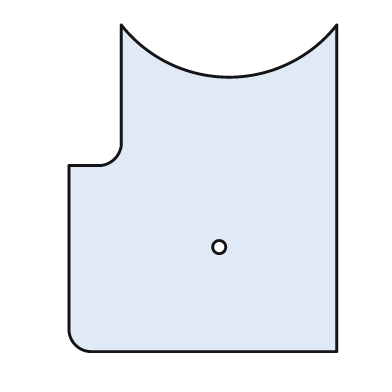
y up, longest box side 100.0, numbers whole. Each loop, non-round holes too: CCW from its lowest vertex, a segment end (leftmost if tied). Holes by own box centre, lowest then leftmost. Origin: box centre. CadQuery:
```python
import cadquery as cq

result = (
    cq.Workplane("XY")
    .moveTo(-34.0, -50.0)
    .lineTo(41.0, -50.0)
    .lineTo(41.0, 50.0)
    .threePointArc((8.0, 34.0), (-25.0, 50.0))
    .lineTo(-25.0, 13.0)
    .threePointArc((-27.0, 9.0), (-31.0, 7.0))
    .lineTo(-41.0, 7.0)
    .lineTo(-41.0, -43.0)
    .threePointArc((-39.0, -48.0), (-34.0, -50.0))
    .close()
    .moveTo(5.0, -18.0)
    .circle(2.0)
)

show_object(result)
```